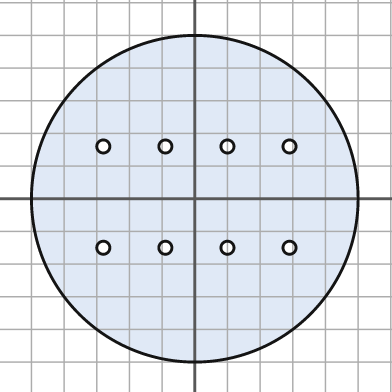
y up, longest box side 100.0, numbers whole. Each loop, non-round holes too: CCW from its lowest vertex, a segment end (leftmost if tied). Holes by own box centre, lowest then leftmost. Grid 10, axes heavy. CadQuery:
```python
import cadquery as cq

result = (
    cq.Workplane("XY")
    .moveTo(0.0, 0.0)
    .circle(50.0)
    .moveTo(-28.0, -15.0)
    .circle(2.0)
    .moveTo(-9.0, -15.0)
    .circle(2.0)
    .moveTo(10.0, -15.0)
    .circle(2.0)
    .moveTo(29.0, -15.0)
    .circle(2.0)
    .moveTo(-28.0, 16.0)
    .circle(2.0)
    .moveTo(-9.0, 16.0)
    .circle(2.0)
    .moveTo(10.0, 16.0)
    .circle(2.0)
    .moveTo(29.0, 16.0)
    .circle(2.0)
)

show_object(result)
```